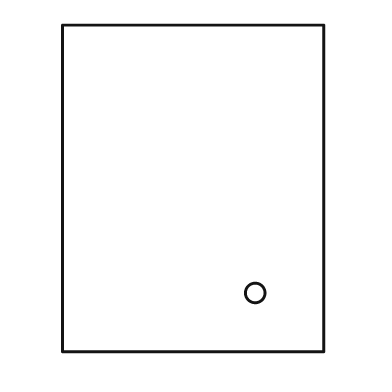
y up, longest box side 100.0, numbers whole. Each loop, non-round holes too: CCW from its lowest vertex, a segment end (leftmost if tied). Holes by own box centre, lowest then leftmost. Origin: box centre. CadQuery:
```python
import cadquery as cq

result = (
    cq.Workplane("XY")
    .moveTo(-40.0, -50.0)
    .lineTo(40.0, -50.0)
    .lineTo(40.0, 50.0)
    .lineTo(-40.0, 50.0)
    .close()
    .moveTo(19.0, -32.0)
    .circle(3.0)
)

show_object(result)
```